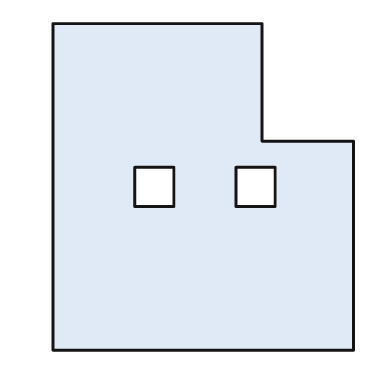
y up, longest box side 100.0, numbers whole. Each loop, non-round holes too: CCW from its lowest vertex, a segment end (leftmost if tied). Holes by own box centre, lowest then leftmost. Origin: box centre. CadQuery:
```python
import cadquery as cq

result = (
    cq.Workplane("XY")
    .moveTo(-46.0, -50.0)
    .lineTo(46.0, -50.0)
    .lineTo(46.0, 14.0)
    .lineTo(18.0, 14.0)
    .lineTo(18.0, 50.0)
    .lineTo(-46.0, 50.0)
    .close()
    .moveTo(-21.0, -6.0)
    .lineTo(-9.0, -6.0)
    .lineTo(-9.0, 6.0)
    .lineTo(-21.0, 6.0)
    .close()
    .moveTo(10.0, -6.0)
    .lineTo(22.0, -6.0)
    .lineTo(22.0, 6.0)
    .lineTo(10.0, 6.0)
    .close()
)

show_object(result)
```